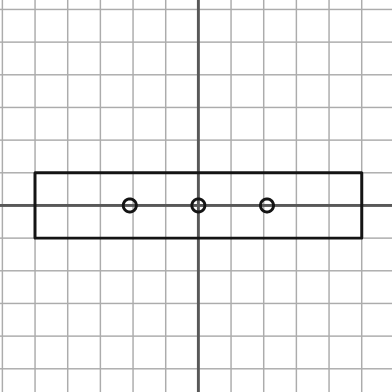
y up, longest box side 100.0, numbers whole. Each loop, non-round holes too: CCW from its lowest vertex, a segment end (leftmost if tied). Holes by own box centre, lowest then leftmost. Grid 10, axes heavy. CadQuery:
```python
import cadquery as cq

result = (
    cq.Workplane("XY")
    .moveTo(-50.0, -10.0)
    .lineTo(50.0, -10.0)
    .lineTo(50.0, 10.0)
    .lineTo(-50.0, 10.0)
    .close()
    .moveTo(-21.0, 0.0)
    .circle(2.0)
    .moveTo(0.0, 0.0)
    .circle(2.0)
    .moveTo(21.0, 0.0)
    .circle(2.0)
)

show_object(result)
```